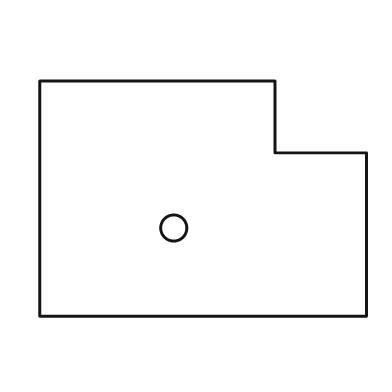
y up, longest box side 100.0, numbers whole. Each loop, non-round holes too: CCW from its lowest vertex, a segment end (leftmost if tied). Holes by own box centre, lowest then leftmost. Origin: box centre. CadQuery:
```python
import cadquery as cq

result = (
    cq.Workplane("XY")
    .moveTo(-50.0, -36.0)
    .lineTo(50.0, -36.0)
    .lineTo(50.0, 14.0)
    .lineTo(22.0, 14.0)
    .lineTo(22.0, 36.0)
    .lineTo(-50.0, 36.0)
    .close()
    .moveTo(-9.0, -9.0)
    .circle(4.0)
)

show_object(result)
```